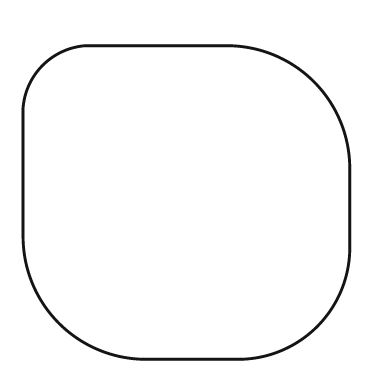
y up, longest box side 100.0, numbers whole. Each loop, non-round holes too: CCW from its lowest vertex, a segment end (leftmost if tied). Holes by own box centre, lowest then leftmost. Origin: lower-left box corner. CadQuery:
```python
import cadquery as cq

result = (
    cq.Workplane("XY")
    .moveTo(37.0, 0.0)
    .lineTo(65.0, 0.0)
    .threePointArc((90.0, 10.0), (100.0, 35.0))
    .lineTo(100.0, 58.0)
    .threePointArc((89.0, 85.0), (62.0, 96.0))
    .lineTo(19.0, 96.0)
    .threePointArc((6.0, 90.0), (0.0, 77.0))
    .lineTo(0.0, 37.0)
    .threePointArc((11.0, 11.0), (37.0, 0.0))
    .close()
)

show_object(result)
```